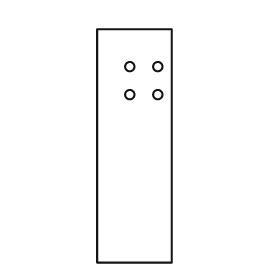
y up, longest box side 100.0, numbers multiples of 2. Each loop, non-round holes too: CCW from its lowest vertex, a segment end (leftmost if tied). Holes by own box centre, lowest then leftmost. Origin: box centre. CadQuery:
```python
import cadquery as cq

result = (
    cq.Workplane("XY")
    .moveTo(-16.0, -50.0)
    .lineTo(16.0, -50.0)
    .lineTo(16.0, 50.0)
    .lineTo(-16.0, 50.0)
    .close()
    .moveTo(-2.0, 22.0)
    .circle(2.0)
    .moveTo(10.0, 22.0)
    .circle(2.0)
    .moveTo(-2.0, 34.0)
    .circle(2.0)
    .moveTo(10.0, 34.0)
    .circle(2.0)
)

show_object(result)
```